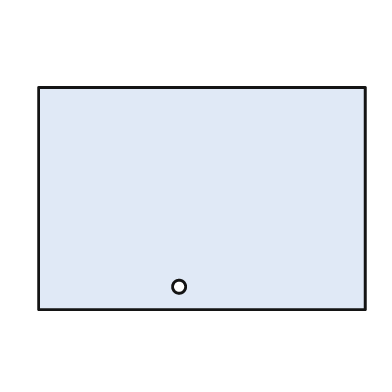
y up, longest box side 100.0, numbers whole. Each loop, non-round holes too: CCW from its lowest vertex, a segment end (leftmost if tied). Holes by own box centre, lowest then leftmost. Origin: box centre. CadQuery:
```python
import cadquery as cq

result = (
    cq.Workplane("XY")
    .moveTo(-50.0, -34.0)
    .lineTo(50.0, -34.0)
    .lineTo(50.0, 34.0)
    .lineTo(-50.0, 34.0)
    .close()
    .moveTo(-7.0, -27.0)
    .circle(2.0)
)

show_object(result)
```